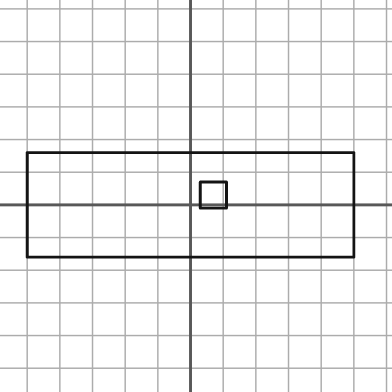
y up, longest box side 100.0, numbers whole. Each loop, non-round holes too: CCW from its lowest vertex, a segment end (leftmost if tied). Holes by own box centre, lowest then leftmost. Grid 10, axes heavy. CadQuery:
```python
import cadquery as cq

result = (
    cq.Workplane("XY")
    .moveTo(-50.0, -16.0)
    .lineTo(50.0, -16.0)
    .lineTo(50.0, 16.0)
    .lineTo(-50.0, 16.0)
    .close()
    .moveTo(3.0, -1.0)
    .lineTo(11.0, -1.0)
    .lineTo(11.0, 7.0)
    .lineTo(3.0, 7.0)
    .close()
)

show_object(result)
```